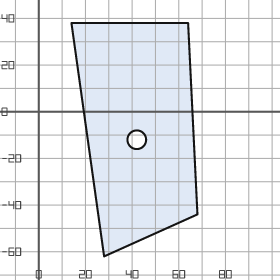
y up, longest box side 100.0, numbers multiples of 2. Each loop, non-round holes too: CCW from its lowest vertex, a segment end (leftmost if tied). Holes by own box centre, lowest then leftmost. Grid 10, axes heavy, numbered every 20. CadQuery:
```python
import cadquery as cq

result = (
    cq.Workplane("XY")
    .moveTo(28.0, -62.0)
    .lineTo(68.0, -44.0)
    .lineTo(64.0, 38.0)
    .lineTo(14.0, 38.0)
    .close()
    .moveTo(42.0, -12.0)
    .circle(4.0)
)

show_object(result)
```